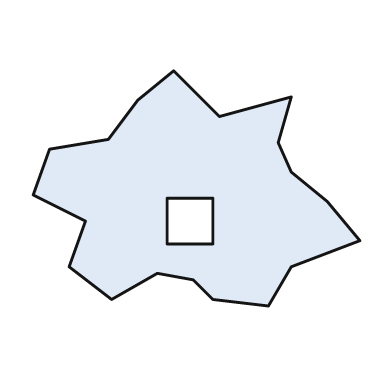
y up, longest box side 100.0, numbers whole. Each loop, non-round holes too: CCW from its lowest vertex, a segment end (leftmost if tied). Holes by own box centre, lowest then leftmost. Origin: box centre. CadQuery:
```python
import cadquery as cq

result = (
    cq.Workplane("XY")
    .moveTo(22.0, -36.0)
    .lineTo(29.0, -24.0)
    .lineTo(50.0, -16.0)
    .lineTo(40.0, -4.0)
    .lineTo(29.0, 5.0)
    .lineTo(25.0, 14.0)
    .lineTo(29.0, 28.0)
    .lineTo(7.0, 22.0)
    .lineTo(-7.0, 36.0)
    .lineTo(-18.0, 27.0)
    .lineTo(-27.0, 15.0)
    .lineTo(-45.0, 12.0)
    .lineTo(-50.0, -2.0)
    .lineTo(-34.0, -10.0)
    .lineTo(-39.0, -24.0)
    .lineTo(-26.0, -34.0)
    .lineTo(-12.0, -26.0)
    .lineTo(-1.0, -28.0)
    .lineTo(5.0, -34.0)
    .close()
    .moveTo(-9.0, -17.0)
    .lineTo(5.0, -17.0)
    .lineTo(5.0, -3.0)
    .lineTo(-9.0, -3.0)
    .close()
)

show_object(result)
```